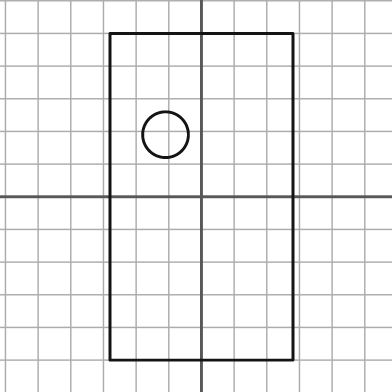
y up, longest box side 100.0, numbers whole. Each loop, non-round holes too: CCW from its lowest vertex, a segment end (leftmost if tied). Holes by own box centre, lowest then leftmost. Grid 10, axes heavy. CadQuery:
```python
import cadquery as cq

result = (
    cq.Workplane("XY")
    .moveTo(-28.0, -50.0)
    .lineTo(28.0, -50.0)
    .lineTo(28.0, 50.0)
    .lineTo(-28.0, 50.0)
    .close()
    .moveTo(-11.0, 19.0)
    .circle(7.0)
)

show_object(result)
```